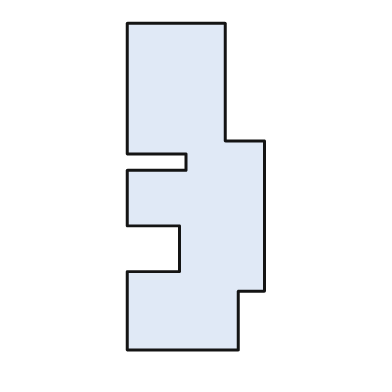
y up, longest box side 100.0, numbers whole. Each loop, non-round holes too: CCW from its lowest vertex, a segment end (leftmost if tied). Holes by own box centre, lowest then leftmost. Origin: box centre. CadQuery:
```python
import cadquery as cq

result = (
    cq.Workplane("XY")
    .moveTo(-21.0, -50.0)
    .lineTo(13.0, -50.0)
    .lineTo(13.0, -32.0)
    .lineTo(21.0, -32.0)
    .lineTo(21.0, 14.0)
    .lineTo(9.0, 14.0)
    .lineTo(9.0, 50.0)
    .lineTo(-21.0, 50.0)
    .lineTo(-21.0, 10.0)
    .lineTo(-3.0, 10.0)
    .lineTo(-3.0, 5.0)
    .lineTo(-21.0, 5.0)
    .lineTo(-21.0, -12.0)
    .lineTo(-5.0, -12.0)
    .lineTo(-5.0, -26.0)
    .lineTo(-21.0, -26.0)
    .close()
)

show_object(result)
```